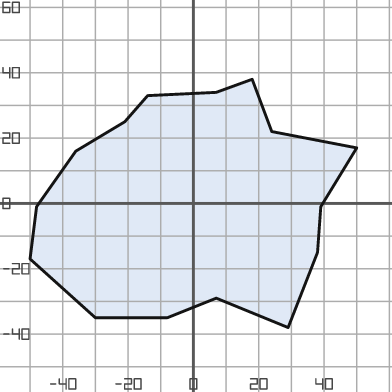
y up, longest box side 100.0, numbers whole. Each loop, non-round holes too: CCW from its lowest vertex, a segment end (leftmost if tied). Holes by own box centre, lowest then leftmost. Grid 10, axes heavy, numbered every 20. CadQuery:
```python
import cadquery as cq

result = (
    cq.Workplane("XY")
    .moveTo(29.0, -38.0)
    .lineTo(38.0, -15.0)
    .lineTo(39.0, -1.0)
    .lineTo(50.0, 17.0)
    .lineTo(24.0, 22.0)
    .lineTo(18.0, 38.0)
    .lineTo(7.0, 34.0)
    .lineTo(-14.0, 33.0)
    .lineTo(-21.0, 25.0)
    .lineTo(-36.0, 16.0)
    .lineTo(-48.0, -1.0)
    .lineTo(-50.0, -17.0)
    .lineTo(-30.0, -35.0)
    .lineTo(-8.0, -35.0)
    .lineTo(7.0, -29.0)
    .close()
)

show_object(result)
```